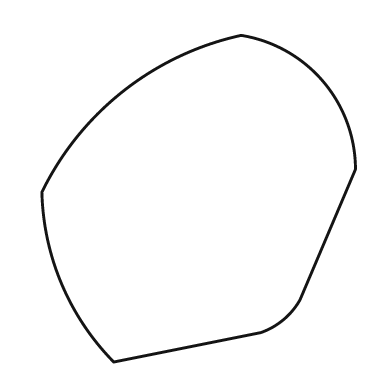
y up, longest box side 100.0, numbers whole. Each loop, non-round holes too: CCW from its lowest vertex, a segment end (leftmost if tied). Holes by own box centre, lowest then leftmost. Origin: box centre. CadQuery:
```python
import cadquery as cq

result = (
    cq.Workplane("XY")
    .moveTo(-26.0, -50.0)
    .lineTo(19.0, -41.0)
    .threePointArc((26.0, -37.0), (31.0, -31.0))
    .lineTo(48.0, 9.0)
    .threePointArc((38.0, 36.0), (13.0, 50.0))
    .threePointArc((-23.0, 33.0), (-48.0, 2.0))
    .threePointArc((-42.0, -26.0), (-26.0, -50.0))
    .close()
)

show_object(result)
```